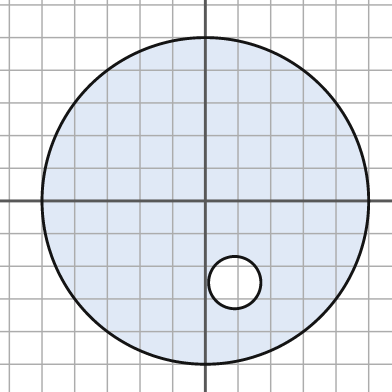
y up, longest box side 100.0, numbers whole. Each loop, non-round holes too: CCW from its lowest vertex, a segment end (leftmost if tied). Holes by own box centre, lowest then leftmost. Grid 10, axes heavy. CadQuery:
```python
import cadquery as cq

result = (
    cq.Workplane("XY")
    .moveTo(0.0, 0.0)
    .circle(50.0)
    .moveTo(9.0, -25.0)
    .circle(8.0)
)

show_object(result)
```